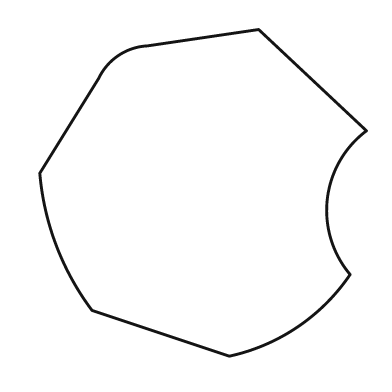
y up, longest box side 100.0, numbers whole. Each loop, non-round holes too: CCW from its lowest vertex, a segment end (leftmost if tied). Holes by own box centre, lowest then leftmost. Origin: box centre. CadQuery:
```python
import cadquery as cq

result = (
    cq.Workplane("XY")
    .moveTo(8.0, -50.0)
    .threePointArc((29.0, -41.0), (45.0, -25.0))
    .threePointArc((38.0, -2.0), (50.0, 19.0))
    .lineTo(17.0, 50.0)
    .lineTo(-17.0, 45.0)
    .threePointArc((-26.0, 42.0), (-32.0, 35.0))
    .lineTo(-50.0, 6.0)
    .threePointArc((-45.0, -16.0), (-34.0, -36.0))
    .close()
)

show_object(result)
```